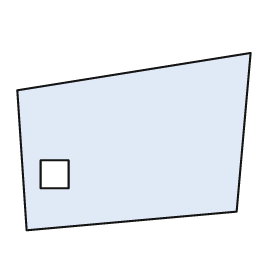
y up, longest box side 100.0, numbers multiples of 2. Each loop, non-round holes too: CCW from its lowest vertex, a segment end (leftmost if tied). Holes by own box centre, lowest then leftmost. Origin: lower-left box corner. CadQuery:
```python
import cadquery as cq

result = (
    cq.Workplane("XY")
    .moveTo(4.0, 0.0)
    .lineTo(94.0, 8.0)
    .lineTo(100.0, 76.0)
    .lineTo(0.0, 60.0)
    .close()
    .moveTo(10.0, 18.0)
    .lineTo(22.0, 18.0)
    .lineTo(22.0, 30.0)
    .lineTo(10.0, 30.0)
    .close()
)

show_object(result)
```